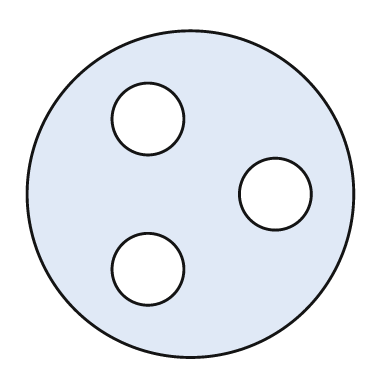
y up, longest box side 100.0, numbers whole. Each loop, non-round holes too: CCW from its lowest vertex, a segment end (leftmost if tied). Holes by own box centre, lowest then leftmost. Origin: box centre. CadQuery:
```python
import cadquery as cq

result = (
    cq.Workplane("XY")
    .moveTo(0.0, 0.0)
    .circle(50.0)
    .moveTo(-13.0, -23.0)
    .circle(11.0)
    .moveTo(26.0, 0.0)
    .circle(11.0)
    .moveTo(-13.0, 23.0)
    .circle(11.0)
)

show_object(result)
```